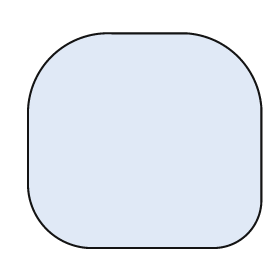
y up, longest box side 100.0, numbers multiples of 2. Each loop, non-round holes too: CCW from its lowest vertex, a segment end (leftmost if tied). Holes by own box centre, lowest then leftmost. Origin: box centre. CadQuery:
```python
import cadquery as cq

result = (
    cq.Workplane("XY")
    .moveTo(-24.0, -46.0)
    .lineTo(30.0, -46.0)
    .threePointArc((44.0, -40.0), (50.0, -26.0))
    .lineTo(50.0, 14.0)
    .threePointArc((40.0, 36.0), (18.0, 46.0))
    .lineTo(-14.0, 46.0)
    .threePointArc((-40.0, 36.0), (-50.0, 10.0))
    .lineTo(-50.0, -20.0)
    .threePointArc((-42.0, -38.0), (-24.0, -46.0))
    .close()
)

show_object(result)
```